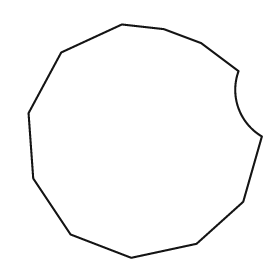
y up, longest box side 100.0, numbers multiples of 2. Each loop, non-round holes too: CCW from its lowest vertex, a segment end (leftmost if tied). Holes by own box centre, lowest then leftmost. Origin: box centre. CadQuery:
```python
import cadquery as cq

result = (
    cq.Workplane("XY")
    .moveTo(-6.0, -50.0)
    .lineTo(22.0, -44.0)
    .lineTo(42.0, -26.0)
    .lineTo(50.0, 2.0)
    .threePointArc((40.0, 14.0), (40.0, 30.0))
    .lineTo(24.0, 42.0)
    .lineTo(8.0, 48.0)
    .lineTo(-10.0, 50.0)
    .lineTo(-36.0, 38.0)
    .lineTo(-50.0, 12.0)
    .lineTo(-48.0, -16.0)
    .lineTo(-32.0, -40.0)
    .close()
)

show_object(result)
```